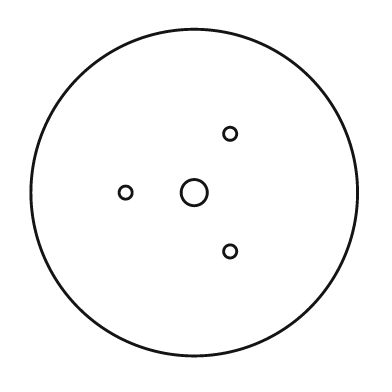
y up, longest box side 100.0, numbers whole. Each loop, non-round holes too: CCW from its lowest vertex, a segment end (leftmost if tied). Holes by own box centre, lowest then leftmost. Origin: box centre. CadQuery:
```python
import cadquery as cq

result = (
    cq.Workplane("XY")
    .moveTo(0.0, 0.0)
    .circle(50.0)
    .moveTo(11.0, -18.0)
    .circle(2.0)
    .moveTo(-21.0, 0.0)
    .circle(2.0)
    .moveTo(0.0, 0.0)
    .circle(4.0)
    .moveTo(11.0, 18.0)
    .circle(2.0)
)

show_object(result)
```